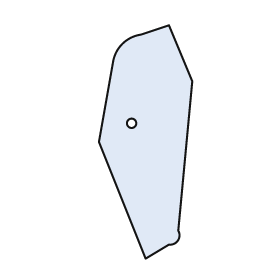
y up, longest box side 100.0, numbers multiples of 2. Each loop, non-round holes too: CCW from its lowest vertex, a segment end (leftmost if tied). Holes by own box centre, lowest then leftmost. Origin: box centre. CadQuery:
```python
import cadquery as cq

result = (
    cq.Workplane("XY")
    .moveTo(0.0, -50.0)
    .lineTo(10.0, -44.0)
    .threePointArc((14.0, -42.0), (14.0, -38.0))
    .lineTo(20.0, 26.0)
    .lineTo(10.0, 50.0)
    .lineTo(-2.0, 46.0)
    .threePointArc((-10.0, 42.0), (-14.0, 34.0))
    .lineTo(-20.0, 0.0)
    .close()
    .moveTo(-6.0, 8.0)
    .circle(2.0)
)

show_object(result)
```